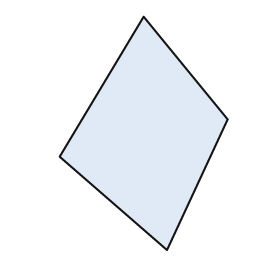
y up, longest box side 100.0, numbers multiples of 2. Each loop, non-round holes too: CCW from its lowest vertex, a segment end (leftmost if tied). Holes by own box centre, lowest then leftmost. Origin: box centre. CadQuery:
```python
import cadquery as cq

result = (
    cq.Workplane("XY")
    .moveTo(10.0, -50.0)
    .lineTo(36.0, 6.0)
    .lineTo(0.0, 50.0)
    .lineTo(-36.0, -10.0)
    .close()
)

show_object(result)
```